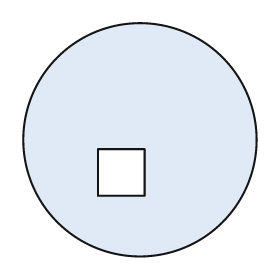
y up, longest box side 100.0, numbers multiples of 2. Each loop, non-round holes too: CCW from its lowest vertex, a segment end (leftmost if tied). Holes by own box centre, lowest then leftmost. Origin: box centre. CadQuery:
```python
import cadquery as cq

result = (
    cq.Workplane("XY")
    .moveTo(0.0, 0.0)
    .circle(50.0)
    .moveTo(-18.0, -24.0)
    .lineTo(2.0, -24.0)
    .lineTo(2.0, -4.0)
    .lineTo(-18.0, -4.0)
    .close()
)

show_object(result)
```